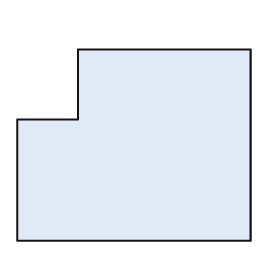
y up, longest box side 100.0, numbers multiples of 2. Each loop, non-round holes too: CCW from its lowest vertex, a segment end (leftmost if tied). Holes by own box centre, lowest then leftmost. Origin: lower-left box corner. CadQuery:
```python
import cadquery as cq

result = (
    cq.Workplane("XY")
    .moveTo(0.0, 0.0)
    .lineTo(100.0, 0.0)
    .lineTo(100.0, 82.0)
    .lineTo(26.0, 82.0)
    .lineTo(26.0, 52.0)
    .lineTo(0.0, 52.0)
    .close()
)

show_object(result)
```